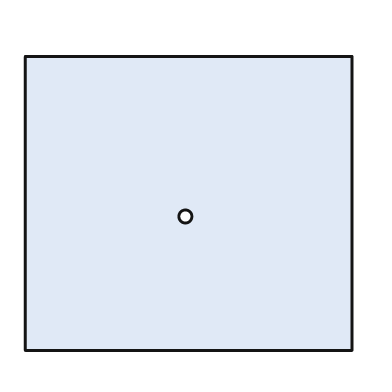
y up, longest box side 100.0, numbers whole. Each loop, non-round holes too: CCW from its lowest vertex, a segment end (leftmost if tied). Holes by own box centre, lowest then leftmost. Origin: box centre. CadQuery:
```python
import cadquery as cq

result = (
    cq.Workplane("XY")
    .moveTo(-50.0, -45.0)
    .lineTo(50.0, -45.0)
    .lineTo(50.0, 45.0)
    .lineTo(-50.0, 45.0)
    .close()
    .moveTo(-1.0, -4.0)
    .circle(2.0)
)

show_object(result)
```